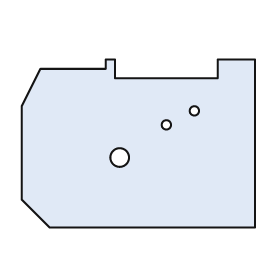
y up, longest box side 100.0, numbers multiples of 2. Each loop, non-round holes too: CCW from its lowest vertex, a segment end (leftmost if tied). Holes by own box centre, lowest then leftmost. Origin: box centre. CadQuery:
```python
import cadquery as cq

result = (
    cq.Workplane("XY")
    .moveTo(-38.0, -36.0)
    .lineTo(50.0, -36.0)
    .lineTo(50.0, 36.0)
    .lineTo(34.0, 36.0)
    .lineTo(34.0, 28.0)
    .lineTo(-10.0, 28.0)
    .lineTo(-10.0, 36.0)
    .lineTo(-14.0, 36.0)
    .lineTo(-14.0, 32.0)
    .lineTo(-42.0, 32.0)
    .lineTo(-50.0, 16.0)
    .lineTo(-50.0, -24.0)
    .close()
    .moveTo(-8.0, -6.0)
    .circle(4.0)
    .moveTo(12.0, 8.0)
    .circle(2.0)
    .moveTo(24.0, 14.0)
    .circle(2.0)
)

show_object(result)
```